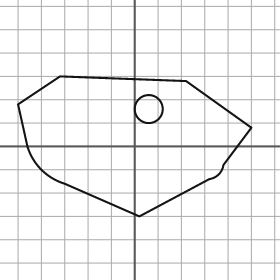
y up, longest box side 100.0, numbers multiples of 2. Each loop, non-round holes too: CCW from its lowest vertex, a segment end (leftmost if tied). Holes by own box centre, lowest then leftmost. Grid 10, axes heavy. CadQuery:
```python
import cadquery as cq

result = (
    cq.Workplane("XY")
    .moveTo(2.0, -30.0)
    .lineTo(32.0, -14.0)
    .threePointArc((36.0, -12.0), (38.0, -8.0))
    .lineTo(50.0, 8.0)
    .lineTo(22.0, 28.0)
    .lineTo(-32.0, 30.0)
    .lineTo(-50.0, 18.0)
    .lineTo(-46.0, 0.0)
    .threePointArc((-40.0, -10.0), (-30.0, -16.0))
    .close()
    .moveTo(6.0, 16.0)
    .circle(6.0)
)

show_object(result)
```